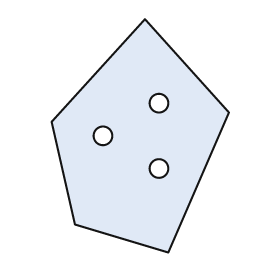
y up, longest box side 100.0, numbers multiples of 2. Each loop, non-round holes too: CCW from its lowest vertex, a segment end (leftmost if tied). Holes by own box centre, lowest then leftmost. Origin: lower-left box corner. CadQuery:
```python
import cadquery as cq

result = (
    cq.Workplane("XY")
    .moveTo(50.0, 0.0)
    .lineTo(76.0, 60.0)
    .lineTo(40.0, 100.0)
    .lineTo(0.0, 56.0)
    .lineTo(10.0, 12.0)
    .close()
    .moveTo(46.0, 36.0)
    .circle(4.0)
    .moveTo(22.0, 50.0)
    .circle(4.0)
    .moveTo(46.0, 64.0)
    .circle(4.0)
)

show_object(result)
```